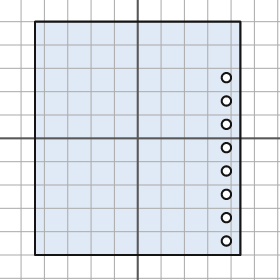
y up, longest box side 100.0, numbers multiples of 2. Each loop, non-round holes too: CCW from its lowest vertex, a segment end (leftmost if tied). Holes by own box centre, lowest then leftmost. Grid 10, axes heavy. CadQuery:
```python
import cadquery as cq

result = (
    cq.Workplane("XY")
    .moveTo(-44.0, -50.0)
    .lineTo(44.0, -50.0)
    .lineTo(44.0, 50.0)
    .lineTo(-44.0, 50.0)
    .close()
    .moveTo(38.0, -44.0)
    .circle(2.0)
    .moveTo(38.0, -34.0)
    .circle(2.0)
    .moveTo(38.0, -24.0)
    .circle(2.0)
    .moveTo(38.0, -14.0)
    .circle(2.0)
    .moveTo(38.0, -4.0)
    .circle(2.0)
    .moveTo(38.0, 6.0)
    .circle(2.0)
    .moveTo(38.0, 16.0)
    .circle(2.0)
    .moveTo(38.0, 26.0)
    .circle(2.0)
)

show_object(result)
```